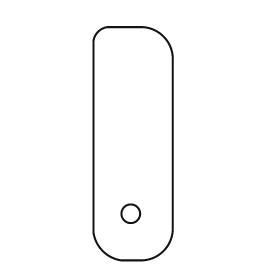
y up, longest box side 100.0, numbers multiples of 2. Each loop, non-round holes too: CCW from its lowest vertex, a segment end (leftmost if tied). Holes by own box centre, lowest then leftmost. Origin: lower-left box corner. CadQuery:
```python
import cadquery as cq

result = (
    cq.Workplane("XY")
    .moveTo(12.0, 0.0)
    .lineTo(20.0, 0.0)
    .threePointArc((30.0, 4.0), (34.0, 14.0))
    .lineTo(34.0, 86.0)
    .threePointArc((30.0, 96.0), (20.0, 100.0))
    .lineTo(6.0, 100.0)
    .threePointArc((2.0, 98.0), (0.0, 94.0))
    .lineTo(0.0, 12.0)
    .threePointArc((4.0, 4.0), (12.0, 0.0))
    .close()
    .moveTo(16.0, 20.0)
    .circle(4.0)
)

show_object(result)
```